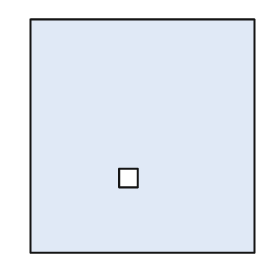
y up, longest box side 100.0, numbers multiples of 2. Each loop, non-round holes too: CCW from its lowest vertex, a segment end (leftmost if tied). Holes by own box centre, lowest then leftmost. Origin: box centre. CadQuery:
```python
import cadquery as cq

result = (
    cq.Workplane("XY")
    .moveTo(-48.0, -50.0)
    .lineTo(48.0, -50.0)
    .lineTo(48.0, 50.0)
    .lineTo(-48.0, 50.0)
    .close()
    .moveTo(-10.0, -22.0)
    .lineTo(-2.0, -22.0)
    .lineTo(-2.0, -14.0)
    .lineTo(-10.0, -14.0)
    .close()
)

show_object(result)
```